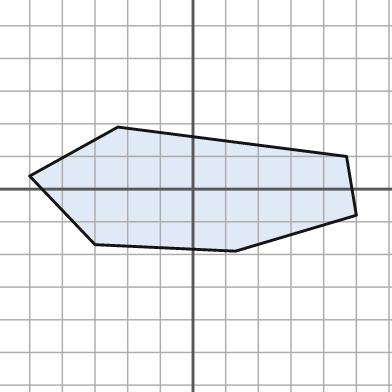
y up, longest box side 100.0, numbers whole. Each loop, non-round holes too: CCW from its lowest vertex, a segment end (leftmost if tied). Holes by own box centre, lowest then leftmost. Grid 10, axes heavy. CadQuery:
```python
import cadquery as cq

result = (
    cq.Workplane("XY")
    .moveTo(13.0, -19.0)
    .lineTo(50.0, -8.0)
    .lineTo(47.0, 10.0)
    .lineTo(-23.0, 19.0)
    .lineTo(-50.0, 4.0)
    .lineTo(-30.0, -17.0)
    .close()
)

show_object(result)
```